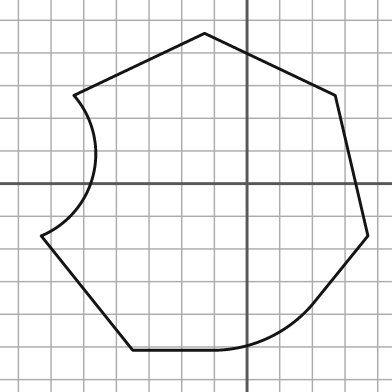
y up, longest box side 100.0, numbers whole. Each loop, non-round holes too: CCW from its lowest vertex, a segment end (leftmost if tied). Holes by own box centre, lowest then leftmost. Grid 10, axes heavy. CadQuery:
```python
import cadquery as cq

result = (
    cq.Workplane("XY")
    .moveTo(-35.0, -51.0)
    .lineTo(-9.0, -51.0)
    .threePointArc((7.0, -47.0), (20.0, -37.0))
    .lineTo(37.0, -16.0)
    .lineTo(27.0, 27.0)
    .lineTo(-13.0, 46.0)
    .lineTo(-53.0, 27.0)
    .threePointArc((-47.0, 3.0), (-63.0, -16.0))
    .close()
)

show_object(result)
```